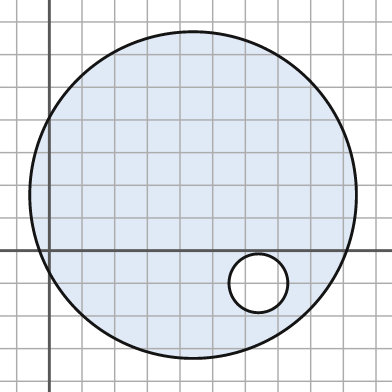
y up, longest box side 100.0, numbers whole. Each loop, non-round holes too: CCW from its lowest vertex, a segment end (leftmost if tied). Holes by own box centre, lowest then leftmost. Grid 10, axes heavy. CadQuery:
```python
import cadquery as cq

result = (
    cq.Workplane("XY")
    .moveTo(44.0, 17.0)
    .circle(50.0)
    .moveTo(64.0, -10.0)
    .circle(9.0)
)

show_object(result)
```